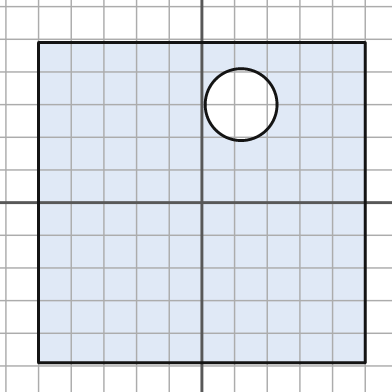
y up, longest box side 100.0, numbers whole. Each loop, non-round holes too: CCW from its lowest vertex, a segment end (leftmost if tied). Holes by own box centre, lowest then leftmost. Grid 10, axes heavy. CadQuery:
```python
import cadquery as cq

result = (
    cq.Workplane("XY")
    .moveTo(-50.0, -49.0)
    .lineTo(50.0, -49.0)
    .lineTo(50.0, 49.0)
    .lineTo(-50.0, 49.0)
    .close()
    .moveTo(12.0, 30.0)
    .circle(11.0)
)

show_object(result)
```